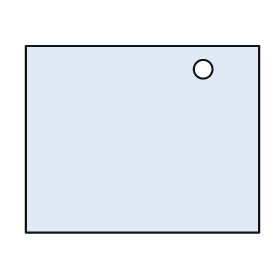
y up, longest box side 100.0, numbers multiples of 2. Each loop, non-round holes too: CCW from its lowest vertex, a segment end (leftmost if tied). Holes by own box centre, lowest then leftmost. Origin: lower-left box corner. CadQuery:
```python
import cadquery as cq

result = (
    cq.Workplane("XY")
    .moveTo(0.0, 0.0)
    .lineTo(100.0, 0.0)
    .lineTo(100.0, 80.0)
    .lineTo(0.0, 80.0)
    .close()
    .moveTo(76.0, 70.0)
    .circle(4.0)
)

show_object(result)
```